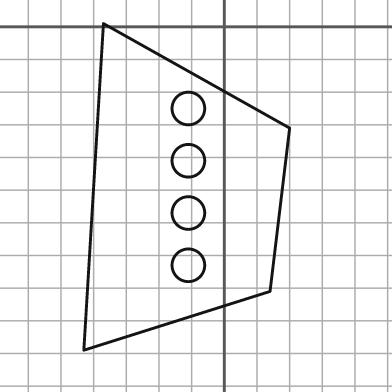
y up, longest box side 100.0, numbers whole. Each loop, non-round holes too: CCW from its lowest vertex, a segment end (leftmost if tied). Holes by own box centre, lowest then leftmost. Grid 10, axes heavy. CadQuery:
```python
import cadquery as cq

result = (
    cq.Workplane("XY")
    .moveTo(-43.0, -99.0)
    .lineTo(14.0, -81.0)
    .lineTo(20.0, -31.0)
    .lineTo(-37.0, 1.0)
    .close()
    .moveTo(-11.0, -73.0)
    .circle(5.0)
    .moveTo(-11.0, -57.0)
    .circle(5.0)
    .moveTo(-11.0, -41.0)
    .circle(5.0)
    .moveTo(-11.0, -25.0)
    .circle(5.0)
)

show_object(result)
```